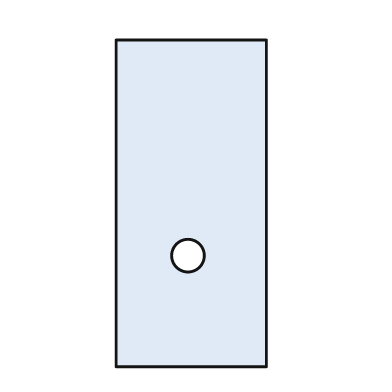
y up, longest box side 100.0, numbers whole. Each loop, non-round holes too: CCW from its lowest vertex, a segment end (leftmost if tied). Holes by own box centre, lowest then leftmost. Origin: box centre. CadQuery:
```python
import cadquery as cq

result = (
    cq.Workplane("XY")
    .moveTo(-23.0, -50.0)
    .lineTo(23.0, -50.0)
    .lineTo(23.0, 50.0)
    .lineTo(-23.0, 50.0)
    .close()
    .moveTo(-1.0, -16.0)
    .circle(5.0)
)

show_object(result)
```